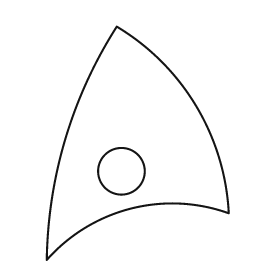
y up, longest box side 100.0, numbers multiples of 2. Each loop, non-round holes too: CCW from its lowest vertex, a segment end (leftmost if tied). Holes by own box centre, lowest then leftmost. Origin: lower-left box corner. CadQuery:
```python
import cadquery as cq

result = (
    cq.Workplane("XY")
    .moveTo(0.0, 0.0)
    .threePointArc((36.0, 22.0), (78.0, 20.0))
    .threePointArc((64.0, 66.0), (30.0, 100.0))
    .threePointArc((8.0, 52.0), (0.0, 0.0))
    .close()
    .moveTo(32.0, 38.0)
    .circle(10.0)
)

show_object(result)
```